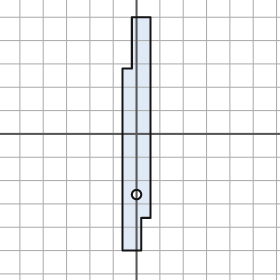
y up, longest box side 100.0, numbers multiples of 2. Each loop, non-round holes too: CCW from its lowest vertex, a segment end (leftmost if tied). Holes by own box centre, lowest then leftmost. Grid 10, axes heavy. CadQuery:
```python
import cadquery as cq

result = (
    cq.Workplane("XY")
    .moveTo(-6.0, -50.0)
    .lineTo(2.0, -50.0)
    .lineTo(2.0, -36.0)
    .lineTo(6.0, -36.0)
    .lineTo(6.0, 50.0)
    .lineTo(-2.0, 50.0)
    .lineTo(-2.0, 28.0)
    .lineTo(-6.0, 28.0)
    .close()
    .moveTo(0.0, -26.0)
    .circle(2.0)
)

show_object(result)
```